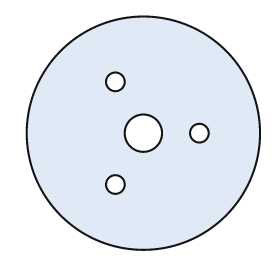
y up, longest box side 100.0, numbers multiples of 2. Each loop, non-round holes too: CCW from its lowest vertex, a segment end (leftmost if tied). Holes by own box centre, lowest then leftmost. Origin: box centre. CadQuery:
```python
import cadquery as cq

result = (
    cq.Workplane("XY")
    .moveTo(0.0, 0.0)
    .circle(50.0)
    .moveTo(-12.0, -22.0)
    .circle(4.0)
    .moveTo(0.0, 0.0)
    .circle(8.0)
    .moveTo(24.0, 0.0)
    .circle(4.0)
    .moveTo(-12.0, 22.0)
    .circle(4.0)
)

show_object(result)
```